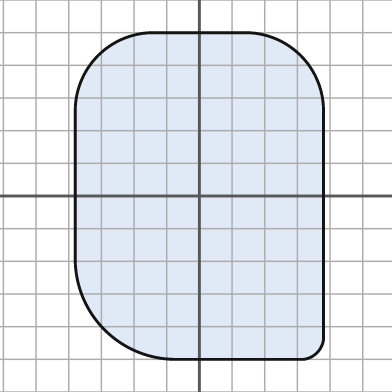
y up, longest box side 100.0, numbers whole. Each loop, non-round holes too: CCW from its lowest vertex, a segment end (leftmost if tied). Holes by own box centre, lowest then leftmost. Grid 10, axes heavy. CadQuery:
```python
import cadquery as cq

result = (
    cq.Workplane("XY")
    .moveTo(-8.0, -50.0)
    .lineTo(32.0, -50.0)
    .threePointArc((36.0, -48.0), (38.0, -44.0))
    .lineTo(38.0, 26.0)
    .threePointArc((31.0, 43.0), (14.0, 50.0))
    .lineTo(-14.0, 50.0)
    .threePointArc((-31.0, 43.0), (-38.0, 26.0))
    .lineTo(-38.0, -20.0)
    .threePointArc((-29.0, -41.0), (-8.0, -50.0))
    .close()
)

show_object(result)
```